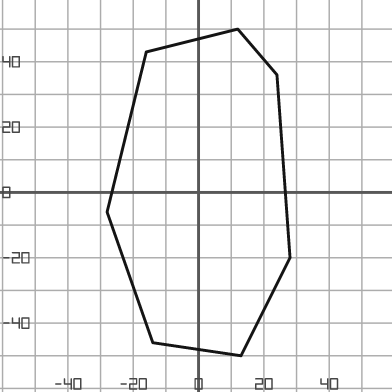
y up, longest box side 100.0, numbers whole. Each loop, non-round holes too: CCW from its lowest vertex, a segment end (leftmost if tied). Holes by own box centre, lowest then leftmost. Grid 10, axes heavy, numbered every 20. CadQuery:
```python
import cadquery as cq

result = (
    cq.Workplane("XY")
    .moveTo(13.0, -50.0)
    .lineTo(28.0, -20.0)
    .lineTo(24.0, 36.0)
    .lineTo(12.0, 50.0)
    .lineTo(-16.0, 43.0)
    .lineTo(-28.0, -6.0)
    .lineTo(-14.0, -46.0)
    .close()
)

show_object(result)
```